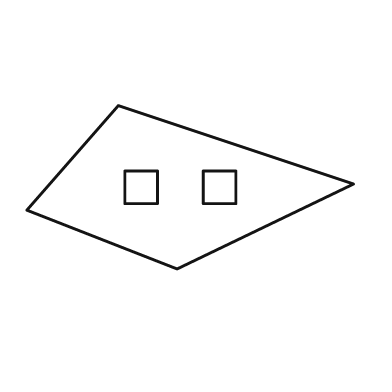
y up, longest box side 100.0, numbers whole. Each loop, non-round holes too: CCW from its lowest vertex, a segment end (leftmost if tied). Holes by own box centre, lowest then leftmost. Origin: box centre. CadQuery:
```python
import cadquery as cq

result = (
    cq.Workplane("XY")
    .moveTo(-4.0, -25.0)
    .lineTo(50.0, 1.0)
    .lineTo(-22.0, 25.0)
    .lineTo(-50.0, -7.0)
    .close()
    .moveTo(-20.0, -5.0)
    .lineTo(-10.0, -5.0)
    .lineTo(-10.0, 5.0)
    .lineTo(-20.0, 5.0)
    .close()
    .moveTo(4.0, -5.0)
    .lineTo(14.0, -5.0)
    .lineTo(14.0, 5.0)
    .lineTo(4.0, 5.0)
    .close()
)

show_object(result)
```